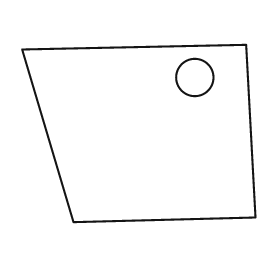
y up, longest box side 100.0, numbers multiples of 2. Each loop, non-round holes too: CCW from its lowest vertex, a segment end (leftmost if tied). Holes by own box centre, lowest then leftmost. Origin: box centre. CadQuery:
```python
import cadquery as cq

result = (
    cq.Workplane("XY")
    .moveTo(-28.0, -38.0)
    .lineTo(50.0, -36.0)
    .lineTo(46.0, 38.0)
    .lineTo(-50.0, 36.0)
    .close()
    .moveTo(24.0, 24.0)
    .circle(8.0)
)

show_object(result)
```